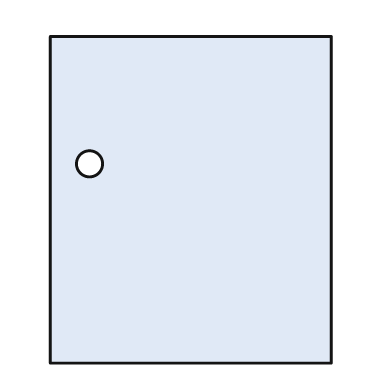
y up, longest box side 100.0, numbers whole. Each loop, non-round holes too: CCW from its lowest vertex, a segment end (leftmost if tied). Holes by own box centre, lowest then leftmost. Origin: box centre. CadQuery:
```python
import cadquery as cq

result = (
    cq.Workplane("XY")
    .moveTo(-43.0, -50.0)
    .lineTo(43.0, -50.0)
    .lineTo(43.0, 50.0)
    .lineTo(-43.0, 50.0)
    .close()
    .moveTo(-31.0, 11.0)
    .circle(4.0)
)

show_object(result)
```